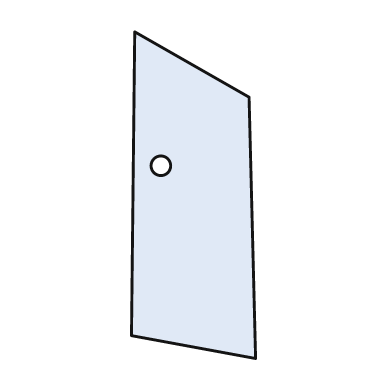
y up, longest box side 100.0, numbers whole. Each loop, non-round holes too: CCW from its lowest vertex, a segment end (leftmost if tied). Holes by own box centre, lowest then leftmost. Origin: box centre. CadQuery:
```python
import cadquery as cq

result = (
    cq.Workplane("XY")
    .moveTo(19.0, -50.0)
    .lineTo(17.0, 30.0)
    .lineTo(-18.0, 50.0)
    .lineTo(-19.0, -43.0)
    .close()
    .moveTo(-10.0, 9.0)
    .circle(3.0)
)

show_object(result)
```